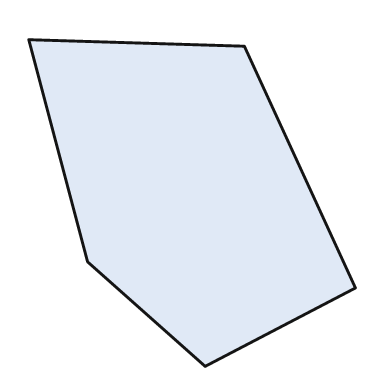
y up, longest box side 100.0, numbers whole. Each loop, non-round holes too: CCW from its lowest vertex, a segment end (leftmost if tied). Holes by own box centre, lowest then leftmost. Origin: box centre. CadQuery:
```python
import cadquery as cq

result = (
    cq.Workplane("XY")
    .moveTo(4.0, -50.0)
    .lineTo(50.0, -26.0)
    .lineTo(16.0, 48.0)
    .lineTo(-50.0, 50.0)
    .lineTo(-32.0, -18.0)
    .close()
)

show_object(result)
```